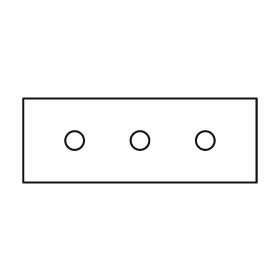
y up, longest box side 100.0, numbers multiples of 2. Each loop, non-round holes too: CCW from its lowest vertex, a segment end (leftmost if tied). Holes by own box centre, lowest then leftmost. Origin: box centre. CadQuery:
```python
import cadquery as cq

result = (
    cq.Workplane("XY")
    .moveTo(-50.0, -18.0)
    .lineTo(50.0, -18.0)
    .lineTo(50.0, 18.0)
    .lineTo(-50.0, 18.0)
    .close()
    .moveTo(-28.0, 0.0)
    .circle(4.0)
    .moveTo(0.0, 0.0)
    .circle(4.0)
    .moveTo(28.0, 0.0)
    .circle(4.0)
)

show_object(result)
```